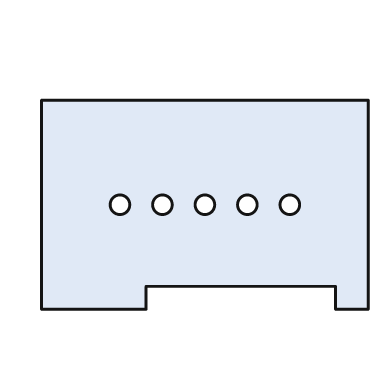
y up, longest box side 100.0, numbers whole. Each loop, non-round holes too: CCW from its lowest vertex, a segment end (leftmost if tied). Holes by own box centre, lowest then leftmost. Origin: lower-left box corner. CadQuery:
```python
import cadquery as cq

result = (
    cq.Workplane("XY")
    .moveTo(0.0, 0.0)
    .lineTo(32.0, 0.0)
    .lineTo(32.0, 7.0)
    .lineTo(90.0, 7.0)
    .lineTo(90.0, 0.0)
    .lineTo(100.0, 0.0)
    .lineTo(100.0, 64.0)
    .lineTo(0.0, 64.0)
    .close()
    .moveTo(24.0, 32.0)
    .circle(3.0)
    .moveTo(37.0, 32.0)
    .circle(3.0)
    .moveTo(50.0, 32.0)
    .circle(3.0)
    .moveTo(63.0, 32.0)
    .circle(3.0)
    .moveTo(76.0, 32.0)
    .circle(3.0)
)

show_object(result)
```